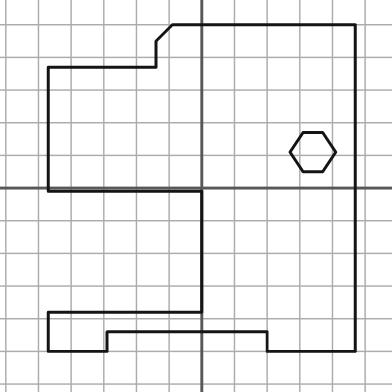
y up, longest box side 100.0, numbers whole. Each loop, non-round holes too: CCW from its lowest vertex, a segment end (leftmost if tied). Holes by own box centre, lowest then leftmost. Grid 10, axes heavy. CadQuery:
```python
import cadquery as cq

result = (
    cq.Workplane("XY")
    .moveTo(-47.0, -50.0)
    .lineTo(-29.0, -50.0)
    .lineTo(-29.0, -44.0)
    .lineTo(20.0, -44.0)
    .lineTo(20.0, -50.0)
    .lineTo(47.0, -50.0)
    .lineTo(47.0, 50.0)
    .lineTo(-9.0, 50.0)
    .lineTo(-14.0, 45.0)
    .lineTo(-14.0, 37.0)
    .lineTo(-47.0, 37.0)
    .lineTo(-47.0, -1.0)
    .lineTo(0.0, -1.0)
    .lineTo(0.0, -38.0)
    .lineTo(-47.0, -38.0)
    .close()
    .moveTo(31.0, 5.0)
    .lineTo(37.0, 5.0)
    .lineTo(41.0, 11.0)
    .lineTo(37.0, 17.0)
    .lineTo(31.0, 17.0)
    .lineTo(27.0, 11.0)
    .close()
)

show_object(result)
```